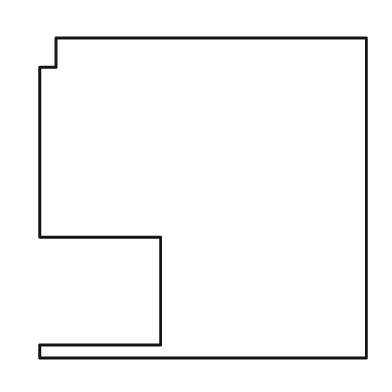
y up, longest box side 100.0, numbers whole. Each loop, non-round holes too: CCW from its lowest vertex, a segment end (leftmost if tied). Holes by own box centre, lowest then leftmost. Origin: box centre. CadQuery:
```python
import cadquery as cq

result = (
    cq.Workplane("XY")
    .moveTo(-50.0, -49.0)
    .lineTo(50.0, -49.0)
    .lineTo(50.0, 49.0)
    .lineTo(-45.0, 49.0)
    .lineTo(-45.0, 40.0)
    .lineTo(-50.0, 40.0)
    .lineTo(-50.0, -12.0)
    .lineTo(-13.0, -12.0)
    .lineTo(-13.0, -45.0)
    .lineTo(-50.0, -45.0)
    .close()
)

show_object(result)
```